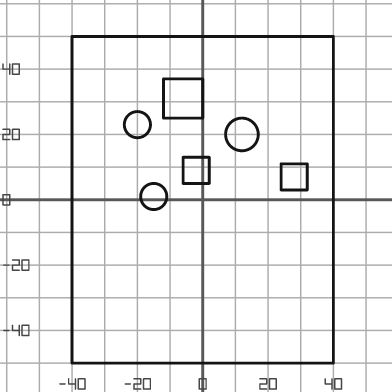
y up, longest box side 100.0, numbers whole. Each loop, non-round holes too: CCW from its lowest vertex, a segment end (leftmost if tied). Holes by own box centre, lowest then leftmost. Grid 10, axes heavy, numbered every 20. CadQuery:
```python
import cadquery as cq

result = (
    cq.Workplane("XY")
    .moveTo(-40.0, -50.0)
    .lineTo(40.0, -50.0)
    .lineTo(40.0, 50.0)
    .lineTo(-40.0, 50.0)
    .close()
    .moveTo(-15.0, 1.0)
    .circle(4.0)
    .moveTo(24.0, 3.0)
    .lineTo(32.0, 3.0)
    .lineTo(32.0, 11.0)
    .lineTo(24.0, 11.0)
    .close()
    .moveTo(-6.0, 5.0)
    .lineTo(2.0, 5.0)
    .lineTo(2.0, 13.0)
    .lineTo(-6.0, 13.0)
    .close()
    .moveTo(12.0, 20.0)
    .circle(5.0)
    .moveTo(-20.0, 23.0)
    .circle(4.0)
    .moveTo(-12.0, 25.0)
    .lineTo(0.0, 25.0)
    .lineTo(0.0, 37.0)
    .lineTo(-12.0, 37.0)
    .close()
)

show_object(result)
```